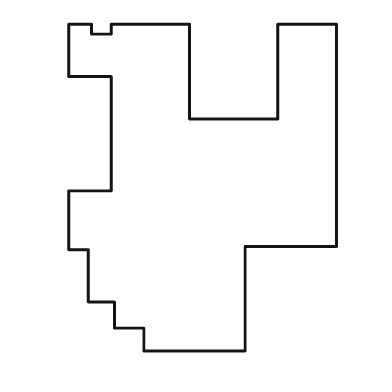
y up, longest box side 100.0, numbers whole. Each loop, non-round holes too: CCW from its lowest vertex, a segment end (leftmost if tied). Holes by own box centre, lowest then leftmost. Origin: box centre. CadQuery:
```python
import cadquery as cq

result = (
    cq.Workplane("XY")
    .moveTo(-18.0, -50.0)
    .lineTo(13.0, -50.0)
    .lineTo(13.0, -18.0)
    .lineTo(41.0, -18.0)
    .lineTo(41.0, 50.0)
    .lineTo(23.0, 50.0)
    .lineTo(23.0, 21.0)
    .lineTo(-4.0, 21.0)
    .lineTo(-4.0, 50.0)
    .lineTo(-28.0, 50.0)
    .lineTo(-28.0, 47.0)
    .lineTo(-34.0, 47.0)
    .lineTo(-34.0, 50.0)
    .lineTo(-41.0, 50.0)
    .lineTo(-41.0, 34.0)
    .lineTo(-28.0, 34.0)
    .lineTo(-28.0, -1.0)
    .lineTo(-41.0, -1.0)
    .lineTo(-41.0, -19.0)
    .lineTo(-35.0, -19.0)
    .lineTo(-35.0, -35.0)
    .lineTo(-27.0, -35.0)
    .lineTo(-27.0, -43.0)
    .lineTo(-18.0, -43.0)
    .close()
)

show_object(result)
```